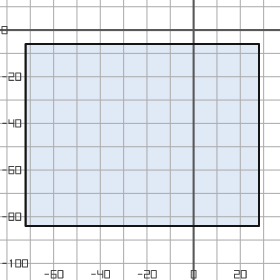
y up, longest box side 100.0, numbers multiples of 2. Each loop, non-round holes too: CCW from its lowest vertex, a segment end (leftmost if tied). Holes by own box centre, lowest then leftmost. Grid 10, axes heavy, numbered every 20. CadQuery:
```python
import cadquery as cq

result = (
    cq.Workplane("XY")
    .moveTo(-72.0, -84.0)
    .lineTo(28.0, -84.0)
    .lineTo(28.0, -6.0)
    .lineTo(-72.0, -6.0)
    .close()
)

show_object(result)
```